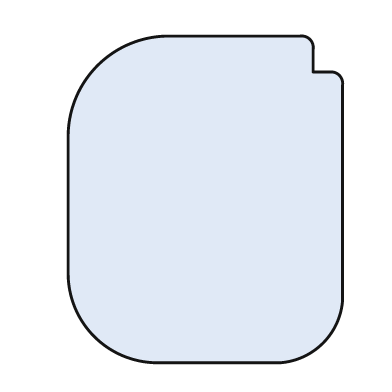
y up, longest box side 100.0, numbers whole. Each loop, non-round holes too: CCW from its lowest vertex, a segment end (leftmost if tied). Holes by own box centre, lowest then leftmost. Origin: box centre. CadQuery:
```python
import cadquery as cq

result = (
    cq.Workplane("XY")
    .moveTo(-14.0, -50.0)
    .lineTo(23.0, -50.0)
    .threePointArc((36.0, -44.0), (42.0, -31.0))
    .lineTo(42.0, 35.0)
    .threePointArc((41.0, 38.0), (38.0, 39.0))
    .lineTo(33.0, 39.0)
    .lineTo(33.0, 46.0)
    .threePointArc((32.0, 49.0), (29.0, 50.0))
    .lineTo(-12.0, 50.0)
    .threePointArc((-33.0, 41.0), (-42.0, 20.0))
    .lineTo(-42.0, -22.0)
    .threePointArc((-34.0, -42.0), (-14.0, -50.0))
    .close()
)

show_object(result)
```